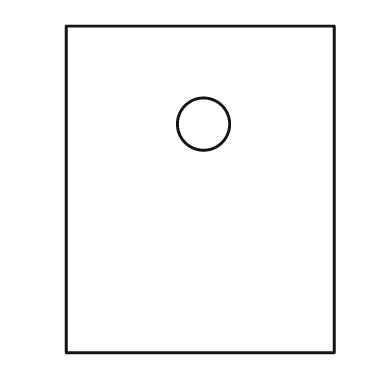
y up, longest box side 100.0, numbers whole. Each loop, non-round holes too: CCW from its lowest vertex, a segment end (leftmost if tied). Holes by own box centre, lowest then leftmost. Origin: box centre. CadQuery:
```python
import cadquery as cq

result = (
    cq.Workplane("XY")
    .moveTo(-41.0, -50.0)
    .lineTo(41.0, -50.0)
    .lineTo(41.0, 50.0)
    .lineTo(-41.0, 50.0)
    .close()
    .moveTo(1.0, 20.0)
    .circle(8.0)
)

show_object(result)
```